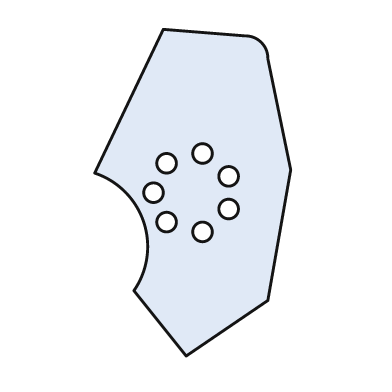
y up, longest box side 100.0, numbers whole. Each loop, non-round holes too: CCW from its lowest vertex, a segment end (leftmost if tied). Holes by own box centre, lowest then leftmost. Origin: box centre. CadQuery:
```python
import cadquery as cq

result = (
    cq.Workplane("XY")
    .moveTo(-2.0, -50.0)
    .lineTo(23.0, -33.0)
    .lineTo(30.0, 7.0)
    .lineTo(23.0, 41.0)
    .threePointArc((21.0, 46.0), (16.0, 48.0))
    .lineTo(-9.0, 50.0)
    .lineTo(-30.0, 6.0)
    .threePointArc((-15.0, -9.0), (-18.0, -30.0))
    .close()
    .moveTo(3.0, -12.0)
    .circle(3.0)
    .moveTo(-8.0, -9.0)
    .circle(3.0)
    .moveTo(11.0, -5.0)
    .circle(3.0)
    .moveTo(-12.0, 0.0)
    .circle(3.0)
    .moveTo(11.0, 5.0)
    .circle(3.0)
    .moveTo(-8.0, 9.0)
    .circle(3.0)
    .moveTo(3.0, 12.0)
    .circle(3.0)
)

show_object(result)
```